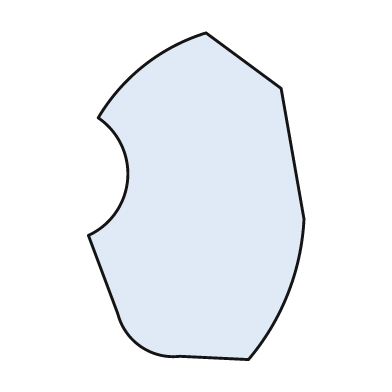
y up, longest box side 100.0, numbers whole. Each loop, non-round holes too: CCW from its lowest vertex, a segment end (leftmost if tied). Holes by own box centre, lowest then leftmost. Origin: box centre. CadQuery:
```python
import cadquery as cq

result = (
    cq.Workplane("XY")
    .moveTo(16.0, -50.0)
    .threePointArc((28.0, -30.0), (33.0, -7.0))
    .lineTo(26.0, 33.0)
    .lineTo(3.0, 50.0)
    .threePointArc((-16.0, 40.0), (-30.0, 24.0))
    .threePointArc((-21.0, 5.0), (-33.0, -12.0))
    .lineTo(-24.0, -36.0)
    .threePointArc((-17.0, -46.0), (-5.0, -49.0))
    .close()
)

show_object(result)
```